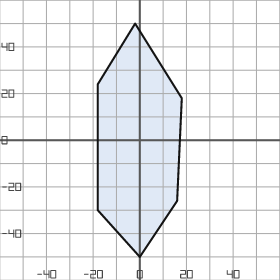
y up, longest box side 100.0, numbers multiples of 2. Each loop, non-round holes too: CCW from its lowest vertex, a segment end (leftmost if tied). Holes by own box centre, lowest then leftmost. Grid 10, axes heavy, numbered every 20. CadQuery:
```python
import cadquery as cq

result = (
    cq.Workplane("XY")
    .moveTo(0.0, -50.0)
    .lineTo(16.0, -26.0)
    .lineTo(18.0, 18.0)
    .lineTo(-2.0, 50.0)
    .lineTo(-18.0, 24.0)
    .lineTo(-18.0, -30.0)
    .close()
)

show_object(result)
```